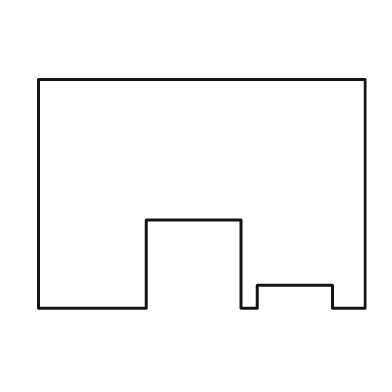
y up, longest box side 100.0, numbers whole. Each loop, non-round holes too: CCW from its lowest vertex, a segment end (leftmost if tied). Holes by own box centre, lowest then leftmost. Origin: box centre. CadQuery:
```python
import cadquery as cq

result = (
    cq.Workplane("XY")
    .moveTo(-50.0, -35.0)
    .lineTo(-17.0, -35.0)
    .lineTo(-17.0, -8.0)
    .lineTo(12.0, -8.0)
    .lineTo(12.0, -35.0)
    .lineTo(17.0, -35.0)
    .lineTo(17.0, -28.0)
    .lineTo(40.0, -28.0)
    .lineTo(40.0, -35.0)
    .lineTo(50.0, -35.0)
    .lineTo(50.0, 35.0)
    .lineTo(-50.0, 35.0)
    .close()
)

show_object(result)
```